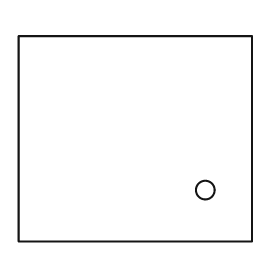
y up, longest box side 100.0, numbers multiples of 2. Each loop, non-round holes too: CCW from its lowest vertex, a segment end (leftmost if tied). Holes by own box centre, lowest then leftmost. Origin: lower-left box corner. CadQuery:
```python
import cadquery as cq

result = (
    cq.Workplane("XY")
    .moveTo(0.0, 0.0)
    .lineTo(100.0, 0.0)
    .lineTo(100.0, 88.0)
    .lineTo(0.0, 88.0)
    .close()
    .moveTo(80.0, 22.0)
    .circle(4.0)
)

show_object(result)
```